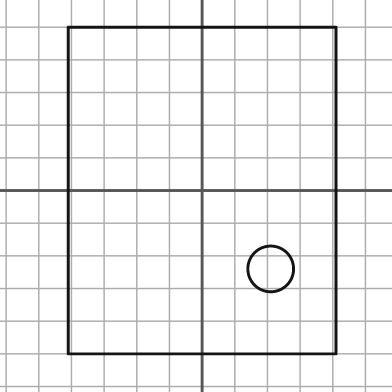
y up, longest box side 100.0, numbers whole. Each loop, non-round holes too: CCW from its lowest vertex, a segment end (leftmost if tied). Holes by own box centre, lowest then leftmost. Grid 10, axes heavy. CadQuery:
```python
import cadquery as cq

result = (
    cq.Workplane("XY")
    .moveTo(-41.0, -50.0)
    .lineTo(41.0, -50.0)
    .lineTo(41.0, 50.0)
    .lineTo(-41.0, 50.0)
    .close()
    .moveTo(21.0, -24.0)
    .circle(7.0)
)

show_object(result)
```